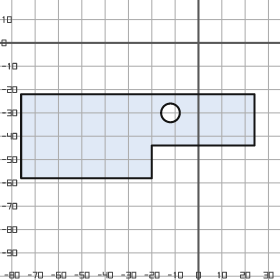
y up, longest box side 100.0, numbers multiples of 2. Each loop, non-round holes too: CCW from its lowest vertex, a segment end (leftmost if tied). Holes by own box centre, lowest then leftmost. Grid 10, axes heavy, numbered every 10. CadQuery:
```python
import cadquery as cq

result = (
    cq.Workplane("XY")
    .moveTo(-76.0, -58.0)
    .lineTo(-20.0, -58.0)
    .lineTo(-20.0, -44.0)
    .lineTo(24.0, -44.0)
    .lineTo(24.0, -22.0)
    .lineTo(-76.0, -22.0)
    .close()
    .moveTo(-12.0, -30.0)
    .circle(4.0)
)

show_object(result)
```